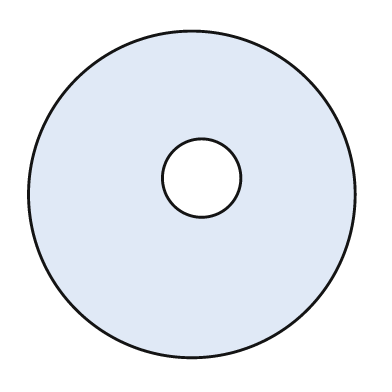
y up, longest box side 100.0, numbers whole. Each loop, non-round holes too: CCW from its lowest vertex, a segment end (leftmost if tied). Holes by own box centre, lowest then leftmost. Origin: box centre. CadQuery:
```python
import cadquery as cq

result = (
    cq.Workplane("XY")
    .moveTo(0.0, 0.0)
    .circle(50.0)
    .moveTo(3.0, 5.0)
    .circle(12.0)
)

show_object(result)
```